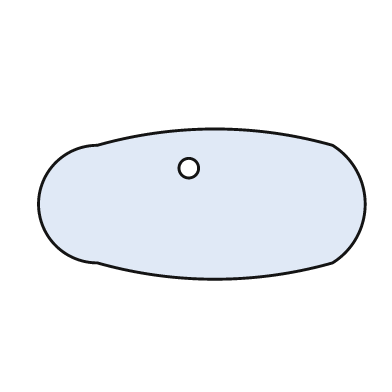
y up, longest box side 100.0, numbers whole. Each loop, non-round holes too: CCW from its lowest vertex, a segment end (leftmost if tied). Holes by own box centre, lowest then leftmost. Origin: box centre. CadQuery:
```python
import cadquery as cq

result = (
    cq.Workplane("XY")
    .moveTo(-32.0, -18.0)
    .threePointArc((4.0, -23.0), (40.0, -18.0))
    .threePointArc((50.0, 0.0), (40.0, 18.0))
    .threePointArc((4.0, 23.0), (-32.0, 18.0))
    .threePointArc((-50.0, 0.0), (-32.0, -18.0))
    .close()
    .moveTo(-4.0, 11.0)
    .circle(3.0)
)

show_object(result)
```